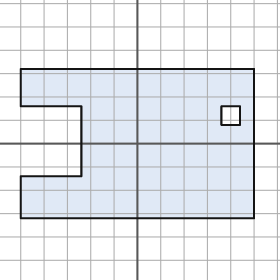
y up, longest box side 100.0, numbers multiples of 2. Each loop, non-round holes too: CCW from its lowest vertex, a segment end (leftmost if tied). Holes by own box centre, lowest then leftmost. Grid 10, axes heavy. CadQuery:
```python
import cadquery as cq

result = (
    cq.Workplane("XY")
    .moveTo(-50.0, -32.0)
    .lineTo(50.0, -32.0)
    .lineTo(50.0, 32.0)
    .lineTo(-50.0, 32.0)
    .lineTo(-50.0, 16.0)
    .lineTo(-24.0, 16.0)
    .lineTo(-24.0, -14.0)
    .lineTo(-50.0, -14.0)
    .close()
    .moveTo(36.0, 8.0)
    .lineTo(44.0, 8.0)
    .lineTo(44.0, 16.0)
    .lineTo(36.0, 16.0)
    .close()
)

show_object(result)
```